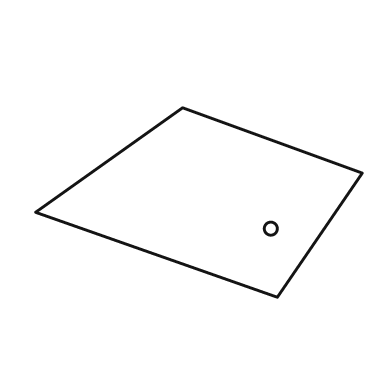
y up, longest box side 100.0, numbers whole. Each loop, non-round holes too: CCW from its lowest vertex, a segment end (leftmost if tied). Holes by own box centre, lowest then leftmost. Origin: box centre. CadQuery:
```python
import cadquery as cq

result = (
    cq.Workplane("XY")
    .moveTo(24.0, -29.0)
    .lineTo(50.0, 9.0)
    .lineTo(-5.0, 29.0)
    .lineTo(-50.0, -3.0)
    .close()
    .moveTo(22.0, -8.0)
    .circle(2.0)
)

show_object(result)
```